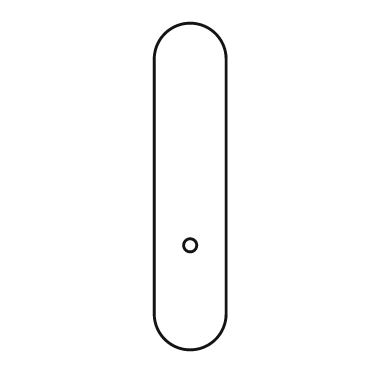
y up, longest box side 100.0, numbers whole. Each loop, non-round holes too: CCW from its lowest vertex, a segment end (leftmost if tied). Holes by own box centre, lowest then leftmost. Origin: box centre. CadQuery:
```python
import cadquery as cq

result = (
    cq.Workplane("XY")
    .moveTo(-11.0, -39.0)
    .threePointArc((0.0, -50.0), (11.0, -39.0))
    .lineTo(11.0, 39.0)
    .threePointArc((0.0, 50.0), (-11.0, 39.0))
    .close()
    .moveTo(0.0, -18.0)
    .circle(2.0)
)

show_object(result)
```